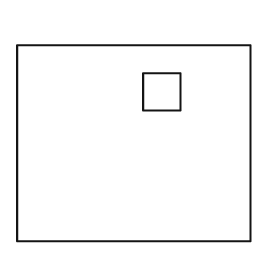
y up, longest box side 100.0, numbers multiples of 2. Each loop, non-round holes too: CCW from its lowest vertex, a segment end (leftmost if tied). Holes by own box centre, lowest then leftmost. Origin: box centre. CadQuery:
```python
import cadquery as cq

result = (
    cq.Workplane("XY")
    .moveTo(-50.0, -42.0)
    .lineTo(50.0, -42.0)
    .lineTo(50.0, 42.0)
    .lineTo(-50.0, 42.0)
    .close()
    .moveTo(4.0, 14.0)
    .lineTo(20.0, 14.0)
    .lineTo(20.0, 30.0)
    .lineTo(4.0, 30.0)
    .close()
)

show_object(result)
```